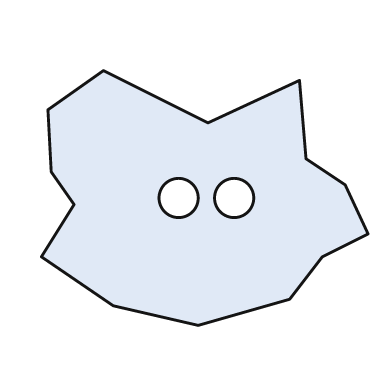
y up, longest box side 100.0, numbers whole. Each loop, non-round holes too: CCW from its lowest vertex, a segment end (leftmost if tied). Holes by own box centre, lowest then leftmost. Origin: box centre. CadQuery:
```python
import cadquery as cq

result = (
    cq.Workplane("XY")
    .moveTo(-2.0, -39.0)
    .lineTo(26.0, -31.0)
    .lineTo(36.0, -18.0)
    .lineTo(50.0, -11.0)
    .lineTo(43.0, 4.0)
    .lineTo(31.0, 12.0)
    .lineTo(29.0, 36.0)
    .lineTo(1.0, 23.0)
    .lineTo(-31.0, 39.0)
    .lineTo(-48.0, 27.0)
    .lineTo(-47.0, 8.0)
    .lineTo(-40.0, -2.0)
    .lineTo(-50.0, -18.0)
    .lineTo(-28.0, -33.0)
    .close()
    .moveTo(-8.0, 0.0)
    .circle(6.0)
    .moveTo(9.0, 0.0)
    .circle(6.0)
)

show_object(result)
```